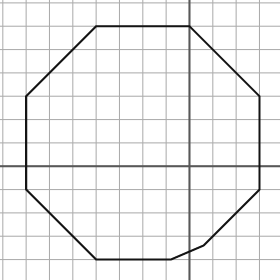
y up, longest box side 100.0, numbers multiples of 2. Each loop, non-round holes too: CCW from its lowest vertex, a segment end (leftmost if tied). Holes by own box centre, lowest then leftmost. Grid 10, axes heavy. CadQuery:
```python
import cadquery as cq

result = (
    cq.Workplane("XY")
    .moveTo(-40.0, -40.0)
    .lineTo(-8.0, -40.0)
    .lineTo(6.0, -34.0)
    .lineTo(30.0, -10.0)
    .lineTo(30.0, 30.0)
    .lineTo(0.0, 60.0)
    .lineTo(-40.0, 60.0)
    .lineTo(-70.0, 30.0)
    .lineTo(-70.0, -10.0)
    .close()
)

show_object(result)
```